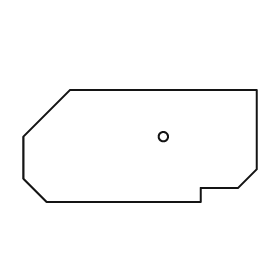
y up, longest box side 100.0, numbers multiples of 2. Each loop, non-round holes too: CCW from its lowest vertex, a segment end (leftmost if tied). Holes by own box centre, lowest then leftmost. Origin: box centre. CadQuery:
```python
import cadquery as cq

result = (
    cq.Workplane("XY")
    .moveTo(-40.0, -24.0)
    .lineTo(26.0, -24.0)
    .lineTo(26.0, -18.0)
    .lineTo(42.0, -18.0)
    .lineTo(50.0, -10.0)
    .lineTo(50.0, 24.0)
    .lineTo(-30.0, 24.0)
    .lineTo(-50.0, 4.0)
    .lineTo(-50.0, -14.0)
    .close()
    .moveTo(10.0, 4.0)
    .circle(2.0)
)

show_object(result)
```